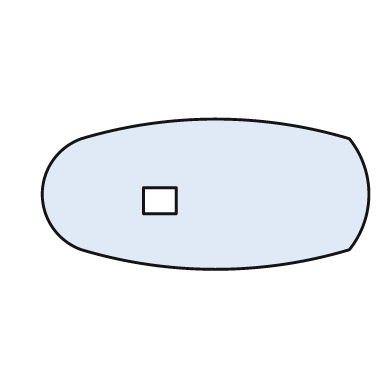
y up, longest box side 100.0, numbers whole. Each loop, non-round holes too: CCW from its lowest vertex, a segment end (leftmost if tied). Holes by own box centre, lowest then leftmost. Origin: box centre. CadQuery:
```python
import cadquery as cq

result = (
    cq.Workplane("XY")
    .moveTo(-38.0, -17.0)
    .threePointArc((3.0, -23.0), (44.0, -17.0))
    .threePointArc((50.0, 0.0), (44.0, 17.0))
    .threePointArc((3.0, 23.0), (-38.0, 17.0))
    .threePointArc((-50.0, 0.0), (-38.0, -17.0))
    .close()
    .moveTo(-19.0, -6.0)
    .lineTo(-9.0, -6.0)
    .lineTo(-9.0, 2.0)
    .lineTo(-19.0, 2.0)
    .close()
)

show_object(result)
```